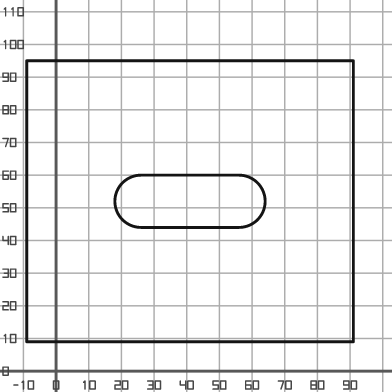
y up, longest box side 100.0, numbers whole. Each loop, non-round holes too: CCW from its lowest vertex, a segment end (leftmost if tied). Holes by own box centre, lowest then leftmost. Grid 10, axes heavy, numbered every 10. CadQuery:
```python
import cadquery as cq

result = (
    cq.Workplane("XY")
    .moveTo(-9.0, 9.0)
    .lineTo(91.0, 9.0)
    .lineTo(91.0, 95.0)
    .lineTo(-9.0, 95.0)
    .close()
    .moveTo(26.0, 44.0)
    .lineTo(56.0, 44.0)
    .threePointArc((64.0, 52.0), (56.0, 60.0))
    .lineTo(26.0, 60.0)
    .threePointArc((18.0, 52.0), (26.0, 44.0))
    .close()
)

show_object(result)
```